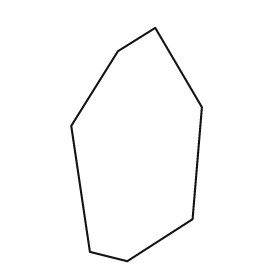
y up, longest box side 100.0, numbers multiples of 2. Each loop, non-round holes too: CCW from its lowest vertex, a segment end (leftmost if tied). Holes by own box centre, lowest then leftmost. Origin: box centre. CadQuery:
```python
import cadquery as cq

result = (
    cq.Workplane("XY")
    .moveTo(-4.0, -50.0)
    .lineTo(24.0, -32.0)
    .lineTo(28.0, 16.0)
    .lineTo(8.0, 50.0)
    .lineTo(-8.0, 40.0)
    .lineTo(-28.0, 8.0)
    .lineTo(-20.0, -46.0)
    .close()
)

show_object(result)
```